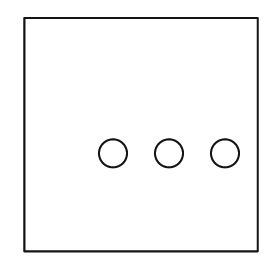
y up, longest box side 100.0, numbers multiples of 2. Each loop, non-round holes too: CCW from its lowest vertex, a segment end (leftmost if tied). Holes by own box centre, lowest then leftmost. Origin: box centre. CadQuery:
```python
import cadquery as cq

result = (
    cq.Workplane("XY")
    .moveTo(-50.0, -50.0)
    .lineTo(50.0, -50.0)
    .lineTo(50.0, 50.0)
    .lineTo(-50.0, 50.0)
    .close()
    .moveTo(-12.0, -8.0)
    .circle(6.0)
    .moveTo(12.0, -8.0)
    .circle(6.0)
    .moveTo(36.0, -8.0)
    .circle(6.0)
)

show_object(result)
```